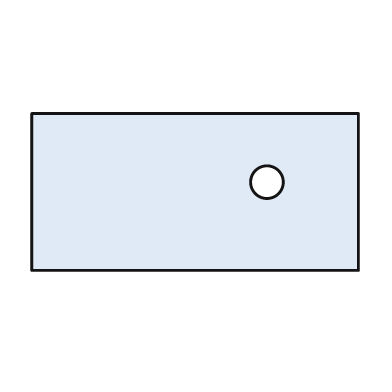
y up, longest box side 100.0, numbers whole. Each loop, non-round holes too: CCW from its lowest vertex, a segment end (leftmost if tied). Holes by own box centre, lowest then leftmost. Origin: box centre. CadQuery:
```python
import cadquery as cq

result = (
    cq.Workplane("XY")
    .moveTo(-50.0, -24.0)
    .lineTo(50.0, -24.0)
    .lineTo(50.0, 24.0)
    .lineTo(-50.0, 24.0)
    .close()
    .moveTo(22.0, 3.0)
    .circle(5.0)
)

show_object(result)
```